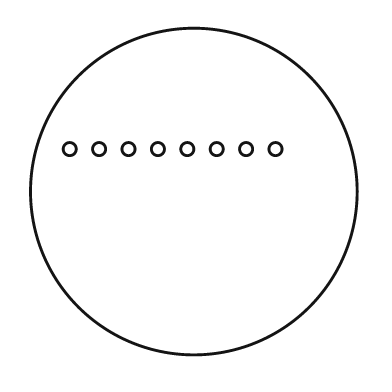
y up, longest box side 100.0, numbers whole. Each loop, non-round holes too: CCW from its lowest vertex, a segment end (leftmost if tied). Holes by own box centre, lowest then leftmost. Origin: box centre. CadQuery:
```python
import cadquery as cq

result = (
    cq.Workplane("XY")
    .moveTo(0.0, 0.0)
    .circle(50.0)
    .moveTo(-38.0, 13.0)
    .circle(2.0)
    .moveTo(-29.0, 13.0)
    .circle(2.0)
    .moveTo(-20.0, 13.0)
    .circle(2.0)
    .moveTo(-11.0, 13.0)
    .circle(2.0)
    .moveTo(-2.0, 13.0)
    .circle(2.0)
    .moveTo(7.0, 13.0)
    .circle(2.0)
    .moveTo(16.0, 13.0)
    .circle(2.0)
    .moveTo(25.0, 13.0)
    .circle(2.0)
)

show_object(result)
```